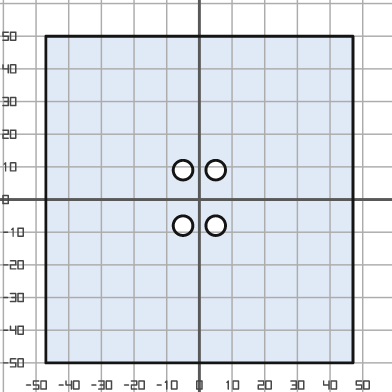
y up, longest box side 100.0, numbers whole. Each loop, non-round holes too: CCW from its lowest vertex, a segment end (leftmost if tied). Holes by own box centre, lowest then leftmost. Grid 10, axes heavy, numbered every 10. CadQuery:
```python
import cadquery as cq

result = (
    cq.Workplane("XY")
    .moveTo(-47.0, -50.0)
    .lineTo(47.0, -50.0)
    .lineTo(47.0, 50.0)
    .lineTo(-47.0, 50.0)
    .close()
    .moveTo(-5.0, -8.0)
    .circle(3.0)
    .moveTo(5.0, -8.0)
    .circle(3.0)
    .moveTo(-5.0, 9.0)
    .circle(3.0)
    .moveTo(5.0, 9.0)
    .circle(3.0)
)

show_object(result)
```